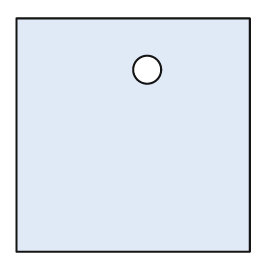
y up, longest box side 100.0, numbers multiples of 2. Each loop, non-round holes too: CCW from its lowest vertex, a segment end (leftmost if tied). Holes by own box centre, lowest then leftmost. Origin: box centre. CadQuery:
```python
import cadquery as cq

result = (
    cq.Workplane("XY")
    .moveTo(-50.0, -50.0)
    .lineTo(50.0, -50.0)
    .lineTo(50.0, 50.0)
    .lineTo(-50.0, 50.0)
    .close()
    .moveTo(6.0, 28.0)
    .circle(6.0)
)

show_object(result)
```